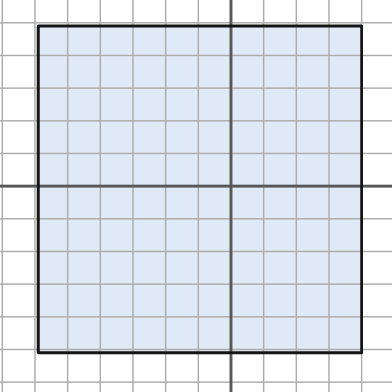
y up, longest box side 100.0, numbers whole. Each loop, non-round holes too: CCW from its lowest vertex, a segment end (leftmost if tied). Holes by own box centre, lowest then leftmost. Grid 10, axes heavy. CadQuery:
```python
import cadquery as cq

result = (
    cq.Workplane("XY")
    .moveTo(-59.0, -51.0)
    .lineTo(40.0, -51.0)
    .lineTo(40.0, 49.0)
    .lineTo(-59.0, 49.0)
    .close()
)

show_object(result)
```